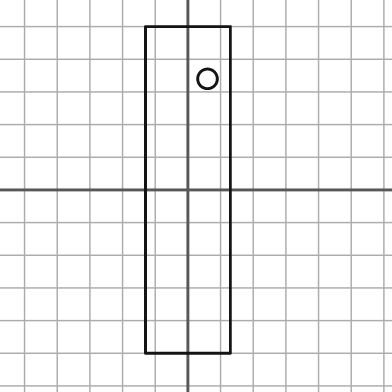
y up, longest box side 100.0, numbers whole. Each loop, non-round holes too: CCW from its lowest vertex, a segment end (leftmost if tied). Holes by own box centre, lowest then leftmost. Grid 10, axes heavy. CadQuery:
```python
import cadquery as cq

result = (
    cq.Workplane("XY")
    .moveTo(-13.0, -50.0)
    .lineTo(13.0, -50.0)
    .lineTo(13.0, 50.0)
    .lineTo(-13.0, 50.0)
    .close()
    .moveTo(6.0, 34.0)
    .circle(3.0)
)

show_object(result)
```